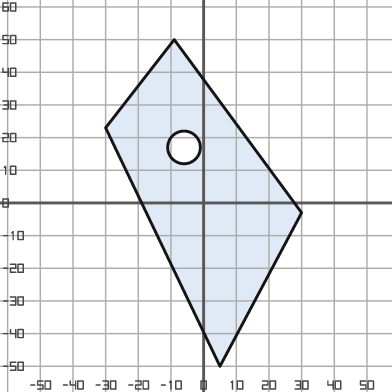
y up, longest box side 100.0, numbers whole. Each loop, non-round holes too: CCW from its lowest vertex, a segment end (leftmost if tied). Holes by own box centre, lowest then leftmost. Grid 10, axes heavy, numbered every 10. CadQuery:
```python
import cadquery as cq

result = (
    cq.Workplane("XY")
    .moveTo(5.0, -50.0)
    .lineTo(30.0, -3.0)
    .lineTo(-9.0, 50.0)
    .lineTo(-30.0, 23.0)
    .close()
    .moveTo(-6.0, 17.0)
    .circle(5.0)
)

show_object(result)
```